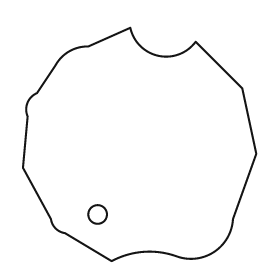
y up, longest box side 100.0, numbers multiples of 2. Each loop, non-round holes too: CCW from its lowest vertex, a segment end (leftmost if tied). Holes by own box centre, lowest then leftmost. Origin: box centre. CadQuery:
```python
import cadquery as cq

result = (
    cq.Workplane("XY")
    .moveTo(-12.0, -50.0)
    .threePointArc((2.0, -46.0), (16.0, -48.0))
    .threePointArc((32.0, -46.0), (40.0, -32.0))
    .lineTo(50.0, -4.0)
    .lineTo(44.0, 24.0)
    .lineTo(24.0, 44.0)
    .threePointArc((8.0, 38.0), (-4.0, 50.0))
    .lineTo(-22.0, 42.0)
    .threePointArc((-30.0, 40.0), (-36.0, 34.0))
    .lineTo(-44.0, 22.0)
    .threePointArc((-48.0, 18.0), (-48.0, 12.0))
    .lineTo(-50.0, -10.0)
    .lineTo(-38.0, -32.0)
    .threePointArc((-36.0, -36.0), (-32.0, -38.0))
    .close()
    .moveTo(-18.0, -30.0)
    .circle(4.0)
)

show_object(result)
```